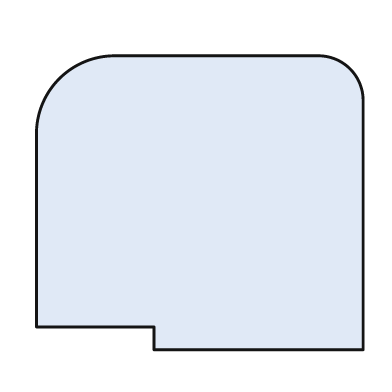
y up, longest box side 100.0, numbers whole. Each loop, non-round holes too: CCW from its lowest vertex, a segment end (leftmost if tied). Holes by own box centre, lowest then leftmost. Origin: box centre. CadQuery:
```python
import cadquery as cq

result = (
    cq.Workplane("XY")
    .moveTo(-14.0, -45.0)
    .lineTo(50.0, -45.0)
    .lineTo(50.0, 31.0)
    .threePointArc((46.0, 41.0), (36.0, 45.0))
    .lineTo(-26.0, 45.0)
    .threePointArc((-43.0, 38.0), (-50.0, 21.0))
    .lineTo(-50.0, -38.0)
    .lineTo(-14.0, -38.0)
    .close()
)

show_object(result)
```